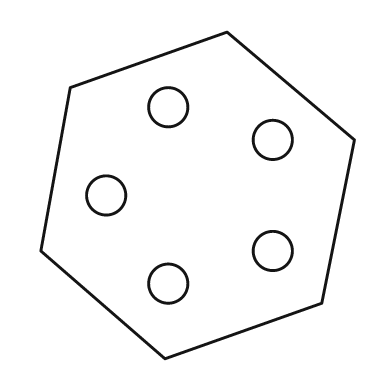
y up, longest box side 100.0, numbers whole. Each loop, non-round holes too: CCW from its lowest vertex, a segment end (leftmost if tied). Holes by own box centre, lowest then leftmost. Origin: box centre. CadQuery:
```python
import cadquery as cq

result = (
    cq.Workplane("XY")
    .moveTo(-10.0, -50.0)
    .lineTo(38.0, -33.0)
    .lineTo(48.0, 17.0)
    .lineTo(9.0, 50.0)
    .lineTo(-39.0, 33.0)
    .lineTo(-48.0, -17.0)
    .close()
    .moveTo(-9.0, -27.0)
    .circle(6.0)
    .moveTo(23.0, -17.0)
    .circle(6.0)
    .moveTo(-28.0, 0.0)
    .circle(6.0)
    .moveTo(23.0, 17.0)
    .circle(6.0)
    .moveTo(-9.0, 27.0)
    .circle(6.0)
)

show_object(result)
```